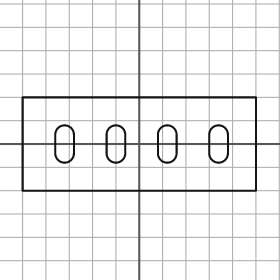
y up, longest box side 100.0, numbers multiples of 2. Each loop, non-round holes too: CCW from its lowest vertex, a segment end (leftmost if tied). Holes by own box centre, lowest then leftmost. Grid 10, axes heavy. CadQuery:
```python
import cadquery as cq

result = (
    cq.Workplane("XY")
    .moveTo(-50.0, -20.0)
    .lineTo(50.0, -20.0)
    .lineTo(50.0, 20.0)
    .lineTo(-50.0, 20.0)
    .close()
    .moveTo(-36.0, -4.0)
    .threePointArc((-32.0, -8.0), (-28.0, -4.0))
    .lineTo(-28.0, 4.0)
    .threePointArc((-32.0, 8.0), (-36.0, 4.0))
    .close()
    .moveTo(-14.0, -4.0)
    .threePointArc((-10.0, -8.0), (-6.0, -4.0))
    .lineTo(-6.0, 4.0)
    .threePointArc((-10.0, 8.0), (-14.0, 4.0))
    .close()
    .moveTo(8.0, -4.0)
    .threePointArc((12.0, -8.0), (16.0, -4.0))
    .lineTo(16.0, 4.0)
    .threePointArc((12.0, 8.0), (8.0, 4.0))
    .close()
    .moveTo(30.0, -4.0)
    .threePointArc((34.0, -8.0), (38.0, -4.0))
    .lineTo(38.0, 4.0)
    .threePointArc((34.0, 8.0), (30.0, 4.0))
    .close()
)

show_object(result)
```